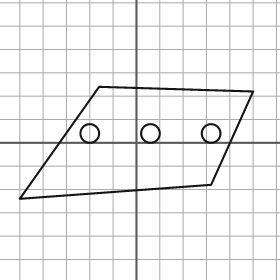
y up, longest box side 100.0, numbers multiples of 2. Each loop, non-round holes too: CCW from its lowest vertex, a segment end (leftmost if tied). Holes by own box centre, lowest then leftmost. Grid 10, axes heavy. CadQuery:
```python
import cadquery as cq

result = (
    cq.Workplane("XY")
    .moveTo(-50.0, -24.0)
    .lineTo(32.0, -18.0)
    .lineTo(50.0, 22.0)
    .lineTo(-16.0, 24.0)
    .close()
    .moveTo(-20.0, 4.0)
    .circle(4.0)
    .moveTo(6.0, 4.0)
    .circle(4.0)
    .moveTo(32.0, 4.0)
    .circle(4.0)
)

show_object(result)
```